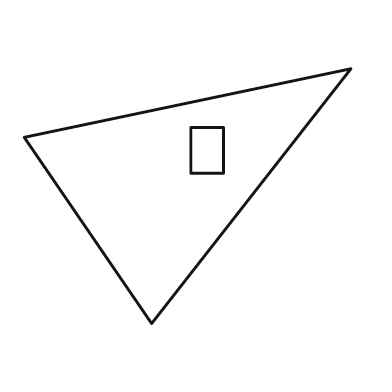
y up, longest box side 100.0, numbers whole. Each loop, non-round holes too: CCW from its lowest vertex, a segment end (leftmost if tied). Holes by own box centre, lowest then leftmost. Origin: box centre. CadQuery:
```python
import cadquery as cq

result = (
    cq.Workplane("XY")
    .moveTo(-11.0, -39.0)
    .lineTo(50.0, 39.0)
    .lineTo(-50.0, 18.0)
    .close()
    .moveTo(1.0, 7.0)
    .lineTo(11.0, 7.0)
    .lineTo(11.0, 21.0)
    .lineTo(1.0, 21.0)
    .close()
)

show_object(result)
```